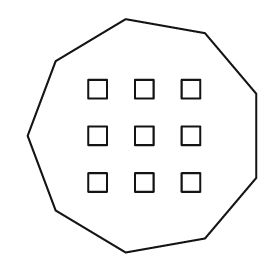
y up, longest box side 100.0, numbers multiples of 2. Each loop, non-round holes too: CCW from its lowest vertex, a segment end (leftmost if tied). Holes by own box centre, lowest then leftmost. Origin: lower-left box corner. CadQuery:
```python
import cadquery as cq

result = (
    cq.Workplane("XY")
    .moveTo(42.0, 0.0)
    .lineTo(76.0, 6.0)
    .lineTo(98.0, 32.0)
    .lineTo(98.0, 68.0)
    .lineTo(76.0, 94.0)
    .lineTo(42.0, 100.0)
    .lineTo(12.0, 82.0)
    .lineTo(0.0, 50.0)
    .lineTo(12.0, 18.0)
    .close()
    .moveTo(26.0, 26.0)
    .lineTo(34.0, 26.0)
    .lineTo(34.0, 34.0)
    .lineTo(26.0, 34.0)
    .close()
    .moveTo(46.0, 26.0)
    .lineTo(54.0, 26.0)
    .lineTo(54.0, 34.0)
    .lineTo(46.0, 34.0)
    .close()
    .moveTo(66.0, 26.0)
    .lineTo(74.0, 26.0)
    .lineTo(74.0, 34.0)
    .lineTo(66.0, 34.0)
    .close()
    .moveTo(26.0, 46.0)
    .lineTo(34.0, 46.0)
    .lineTo(34.0, 54.0)
    .lineTo(26.0, 54.0)
    .close()
    .moveTo(46.0, 46.0)
    .lineTo(54.0, 46.0)
    .lineTo(54.0, 54.0)
    .lineTo(46.0, 54.0)
    .close()
    .moveTo(66.0, 46.0)
    .lineTo(74.0, 46.0)
    .lineTo(74.0, 54.0)
    .lineTo(66.0, 54.0)
    .close()
    .moveTo(26.0, 66.0)
    .lineTo(34.0, 66.0)
    .lineTo(34.0, 74.0)
    .lineTo(26.0, 74.0)
    .close()
    .moveTo(46.0, 66.0)
    .lineTo(54.0, 66.0)
    .lineTo(54.0, 74.0)
    .lineTo(46.0, 74.0)
    .close()
    .moveTo(66.0, 66.0)
    .lineTo(74.0, 66.0)
    .lineTo(74.0, 74.0)
    .lineTo(66.0, 74.0)
    .close()
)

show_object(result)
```